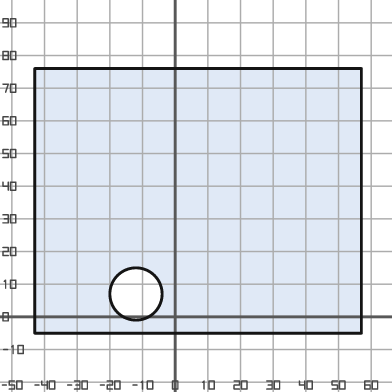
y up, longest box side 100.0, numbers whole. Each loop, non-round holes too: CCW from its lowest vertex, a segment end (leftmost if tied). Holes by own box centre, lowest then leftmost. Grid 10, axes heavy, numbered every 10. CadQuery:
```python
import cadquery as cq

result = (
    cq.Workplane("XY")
    .moveTo(-43.0, -5.0)
    .lineTo(57.0, -5.0)
    .lineTo(57.0, 76.0)
    .lineTo(-43.0, 76.0)
    .close()
    .moveTo(-12.0, 7.0)
    .circle(8.0)
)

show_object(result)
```